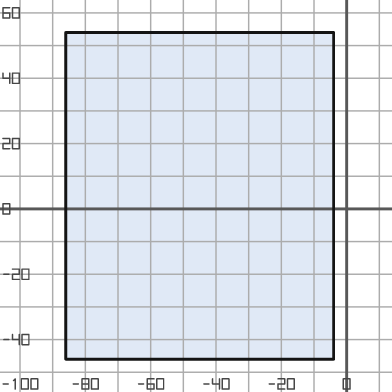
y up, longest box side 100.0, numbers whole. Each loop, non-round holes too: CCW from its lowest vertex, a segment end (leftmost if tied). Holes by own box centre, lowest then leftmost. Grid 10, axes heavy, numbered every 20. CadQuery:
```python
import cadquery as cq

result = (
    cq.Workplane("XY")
    .moveTo(-86.0, -46.0)
    .lineTo(-4.0, -46.0)
    .lineTo(-4.0, 54.0)
    .lineTo(-86.0, 54.0)
    .close()
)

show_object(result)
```